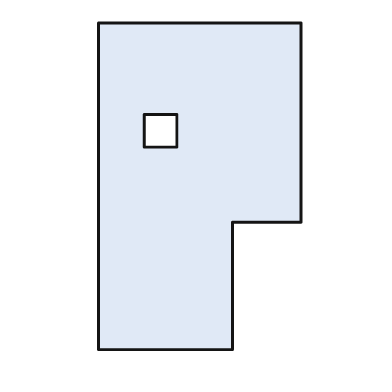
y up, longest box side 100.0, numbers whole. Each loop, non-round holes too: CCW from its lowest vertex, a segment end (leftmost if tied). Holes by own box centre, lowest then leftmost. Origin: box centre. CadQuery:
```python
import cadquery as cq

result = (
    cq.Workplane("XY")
    .moveTo(-31.0, -50.0)
    .lineTo(10.0, -50.0)
    .lineTo(10.0, -11.0)
    .lineTo(31.0, -11.0)
    .lineTo(31.0, 50.0)
    .lineTo(-31.0, 50.0)
    .close()
    .moveTo(-17.0, 12.0)
    .lineTo(-7.0, 12.0)
    .lineTo(-7.0, 22.0)
    .lineTo(-17.0, 22.0)
    .close()
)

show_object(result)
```